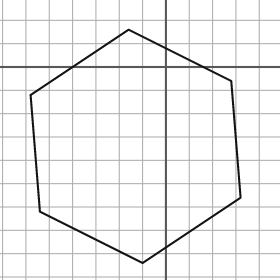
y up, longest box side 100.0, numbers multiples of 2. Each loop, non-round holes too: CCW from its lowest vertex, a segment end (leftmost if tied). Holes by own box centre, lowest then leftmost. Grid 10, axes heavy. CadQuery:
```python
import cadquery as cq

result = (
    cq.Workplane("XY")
    .moveTo(-10.0, -84.0)
    .lineTo(32.0, -56.0)
    .lineTo(28.0, -6.0)
    .lineTo(-16.0, 16.0)
    .lineTo(-58.0, -12.0)
    .lineTo(-54.0, -62.0)
    .close()
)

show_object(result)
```